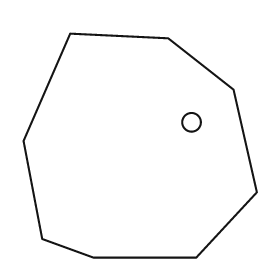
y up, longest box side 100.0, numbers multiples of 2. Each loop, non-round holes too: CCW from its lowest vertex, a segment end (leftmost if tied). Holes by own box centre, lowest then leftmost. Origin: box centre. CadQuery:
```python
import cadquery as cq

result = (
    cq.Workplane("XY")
    .moveTo(-20.0, -48.0)
    .lineTo(24.0, -48.0)
    .lineTo(50.0, -20.0)
    .lineTo(40.0, 24.0)
    .lineTo(12.0, 46.0)
    .lineTo(-30.0, 48.0)
    .lineTo(-50.0, 2.0)
    .lineTo(-42.0, -40.0)
    .close()
    .moveTo(22.0, 10.0)
    .circle(4.0)
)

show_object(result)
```